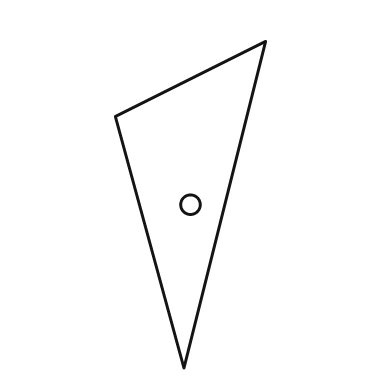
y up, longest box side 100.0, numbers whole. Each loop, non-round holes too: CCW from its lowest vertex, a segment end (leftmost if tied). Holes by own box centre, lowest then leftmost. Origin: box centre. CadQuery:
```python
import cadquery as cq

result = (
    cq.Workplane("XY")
    .moveTo(-2.0, -50.0)
    .lineTo(23.0, 50.0)
    .lineTo(-23.0, 27.0)
    .close()
    .moveTo(0.0, 0.0)
    .circle(3.0)
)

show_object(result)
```